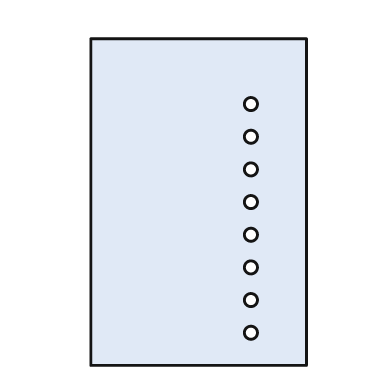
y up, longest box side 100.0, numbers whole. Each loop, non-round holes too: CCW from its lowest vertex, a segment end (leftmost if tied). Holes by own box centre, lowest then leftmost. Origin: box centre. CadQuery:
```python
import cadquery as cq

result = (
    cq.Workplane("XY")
    .moveTo(-33.0, -50.0)
    .lineTo(33.0, -50.0)
    .lineTo(33.0, 50.0)
    .lineTo(-33.0, 50.0)
    .close()
    .moveTo(16.0, -40.0)
    .circle(2.0)
    .moveTo(16.0, -30.0)
    .circle(2.0)
    .moveTo(16.0, -20.0)
    .circle(2.0)
    .moveTo(16.0, -10.0)
    .circle(2.0)
    .moveTo(16.0, 0.0)
    .circle(2.0)
    .moveTo(16.0, 10.0)
    .circle(2.0)
    .moveTo(16.0, 20.0)
    .circle(2.0)
    .moveTo(16.0, 30.0)
    .circle(2.0)
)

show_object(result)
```